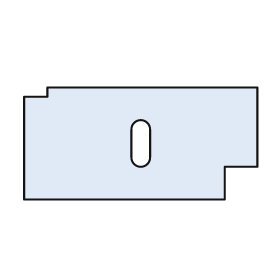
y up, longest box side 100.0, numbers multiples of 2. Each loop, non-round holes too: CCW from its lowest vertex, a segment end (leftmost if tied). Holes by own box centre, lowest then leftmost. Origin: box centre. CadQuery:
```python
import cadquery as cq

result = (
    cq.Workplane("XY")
    .moveTo(-50.0, -24.0)
    .lineTo(36.0, -24.0)
    .lineTo(36.0, -10.0)
    .lineTo(50.0, -10.0)
    .lineTo(50.0, 24.0)
    .lineTo(-40.0, 24.0)
    .lineTo(-40.0, 20.0)
    .lineTo(-50.0, 20.0)
    .close()
    .moveTo(-4.0, -6.0)
    .threePointArc((0.0, -10.0), (4.0, -6.0))
    .lineTo(4.0, 6.0)
    .threePointArc((0.0, 10.0), (-4.0, 6.0))
    .close()
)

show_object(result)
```